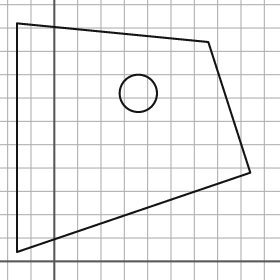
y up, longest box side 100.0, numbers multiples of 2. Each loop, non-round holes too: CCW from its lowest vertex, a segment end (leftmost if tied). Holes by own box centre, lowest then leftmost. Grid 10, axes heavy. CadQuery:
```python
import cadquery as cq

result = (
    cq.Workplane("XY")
    .moveTo(-16.0, 4.0)
    .lineTo(84.0, 38.0)
    .lineTo(66.0, 94.0)
    .lineTo(-16.0, 102.0)
    .close()
    .moveTo(36.0, 72.0)
    .circle(8.0)
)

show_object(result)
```